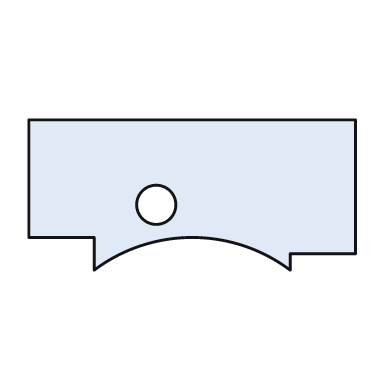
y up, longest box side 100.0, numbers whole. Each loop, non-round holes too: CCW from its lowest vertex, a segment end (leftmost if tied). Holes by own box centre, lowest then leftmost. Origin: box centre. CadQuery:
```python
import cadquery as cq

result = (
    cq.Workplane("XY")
    .moveTo(-30.0, -23.0)
    .threePointArc((0.0, -13.0), (30.0, -23.0))
    .lineTo(30.0, -18.0)
    .lineTo(50.0, -18.0)
    .lineTo(50.0, 23.0)
    .lineTo(-50.0, 23.0)
    .lineTo(-50.0, -13.0)
    .lineTo(-30.0, -13.0)
    .close()
    .moveTo(-11.0, -3.0)
    .circle(6.0)
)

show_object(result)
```